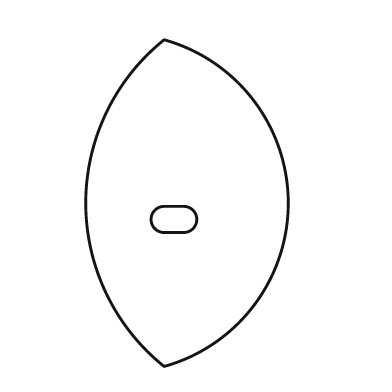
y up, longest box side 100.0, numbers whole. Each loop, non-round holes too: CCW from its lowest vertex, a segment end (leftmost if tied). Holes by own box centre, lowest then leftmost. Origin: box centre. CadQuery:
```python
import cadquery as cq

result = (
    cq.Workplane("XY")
    .moveTo(-7.0, -50.0)
    .threePointArc((31.0, 0.0), (-7.0, 50.0))
    .threePointArc((-31.0, 0.0), (-7.0, -50.0))
    .close()
    .moveTo(-7.0, -9.0)
    .lineTo(-1.0, -9.0)
    .threePointArc((3.0, -5.0), (-1.0, -1.0))
    .lineTo(-7.0, -1.0)
    .threePointArc((-11.0, -5.0), (-7.0, -9.0))
    .close()
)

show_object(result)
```